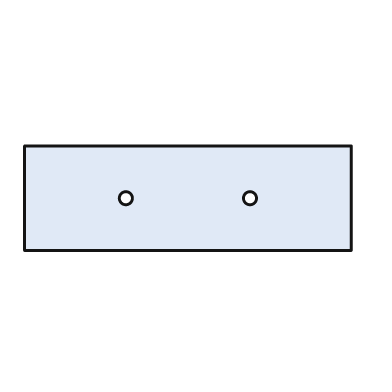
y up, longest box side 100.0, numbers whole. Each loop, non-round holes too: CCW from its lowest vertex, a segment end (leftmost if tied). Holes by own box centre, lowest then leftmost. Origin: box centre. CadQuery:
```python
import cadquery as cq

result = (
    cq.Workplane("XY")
    .moveTo(-50.0, -16.0)
    .lineTo(50.0, -16.0)
    .lineTo(50.0, 16.0)
    .lineTo(-50.0, 16.0)
    .close()
    .moveTo(-19.0, 0.0)
    .circle(2.0)
    .moveTo(19.0, 0.0)
    .circle(2.0)
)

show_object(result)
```